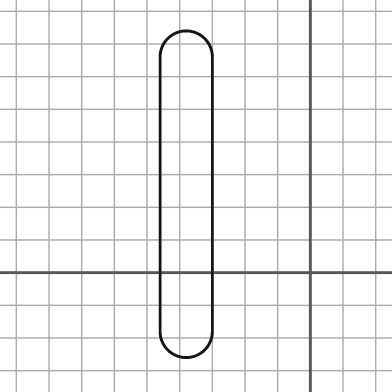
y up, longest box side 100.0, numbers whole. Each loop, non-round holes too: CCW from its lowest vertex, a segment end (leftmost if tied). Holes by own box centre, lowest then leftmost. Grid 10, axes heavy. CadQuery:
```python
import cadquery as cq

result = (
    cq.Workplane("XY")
    .moveTo(-46.0, -18.0)
    .threePointArc((-38.0, -26.0), (-30.0, -18.0))
    .lineTo(-30.0, 66.0)
    .threePointArc((-38.0, 74.0), (-46.0, 66.0))
    .close()
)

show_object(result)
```